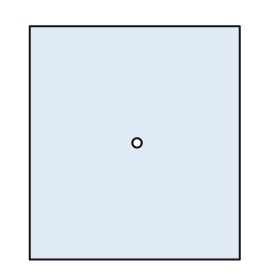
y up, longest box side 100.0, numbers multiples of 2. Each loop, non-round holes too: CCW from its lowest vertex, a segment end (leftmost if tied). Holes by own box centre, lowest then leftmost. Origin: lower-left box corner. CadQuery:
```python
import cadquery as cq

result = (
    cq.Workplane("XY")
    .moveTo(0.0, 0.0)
    .lineTo(90.0, 0.0)
    .lineTo(90.0, 100.0)
    .lineTo(0.0, 100.0)
    .close()
    .moveTo(46.0, 50.0)
    .circle(2.0)
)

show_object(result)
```